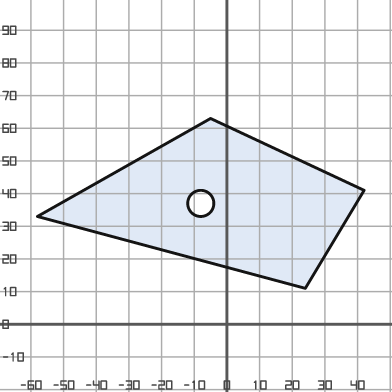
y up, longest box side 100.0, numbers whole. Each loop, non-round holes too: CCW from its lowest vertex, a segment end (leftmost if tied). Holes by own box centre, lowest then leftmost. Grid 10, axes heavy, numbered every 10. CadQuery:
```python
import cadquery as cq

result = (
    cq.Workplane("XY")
    .moveTo(24.0, 11.0)
    .lineTo(42.0, 41.0)
    .lineTo(-5.0, 63.0)
    .lineTo(-58.0, 33.0)
    .close()
    .moveTo(-8.0, 37.0)
    .circle(4.0)
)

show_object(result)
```